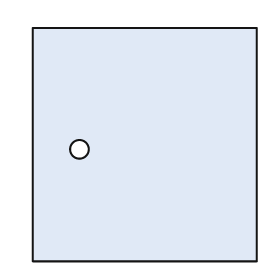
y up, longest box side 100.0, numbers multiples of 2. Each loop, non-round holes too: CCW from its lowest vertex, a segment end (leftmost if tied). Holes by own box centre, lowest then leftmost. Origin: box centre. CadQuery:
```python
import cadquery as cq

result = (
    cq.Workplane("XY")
    .moveTo(-48.0, -50.0)
    .lineTo(48.0, -50.0)
    .lineTo(48.0, 50.0)
    .lineTo(-48.0, 50.0)
    .close()
    .moveTo(-28.0, -2.0)
    .circle(4.0)
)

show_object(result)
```